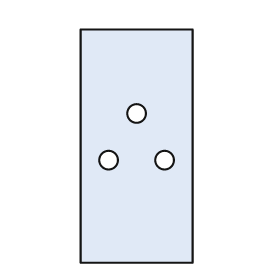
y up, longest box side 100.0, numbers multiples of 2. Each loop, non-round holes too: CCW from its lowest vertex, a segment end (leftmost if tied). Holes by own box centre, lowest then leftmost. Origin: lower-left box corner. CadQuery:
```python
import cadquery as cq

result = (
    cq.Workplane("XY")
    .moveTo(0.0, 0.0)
    .lineTo(48.0, 0.0)
    .lineTo(48.0, 100.0)
    .lineTo(0.0, 100.0)
    .close()
    .moveTo(12.0, 44.0)
    .circle(4.0)
    .moveTo(36.0, 44.0)
    .circle(4.0)
    .moveTo(24.0, 64.0)
    .circle(4.0)
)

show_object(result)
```